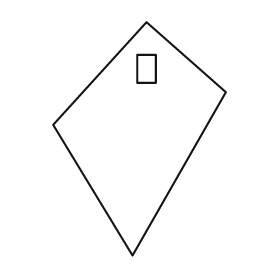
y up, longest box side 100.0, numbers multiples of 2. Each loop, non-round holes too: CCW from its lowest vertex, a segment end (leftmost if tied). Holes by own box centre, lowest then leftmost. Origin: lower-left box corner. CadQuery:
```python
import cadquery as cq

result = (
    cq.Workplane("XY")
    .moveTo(34.0, 0.0)
    .lineTo(74.0, 70.0)
    .lineTo(40.0, 100.0)
    .lineTo(0.0, 56.0)
    .close()
    .moveTo(36.0, 74.0)
    .lineTo(44.0, 74.0)
    .lineTo(44.0, 86.0)
    .lineTo(36.0, 86.0)
    .close()
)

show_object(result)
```